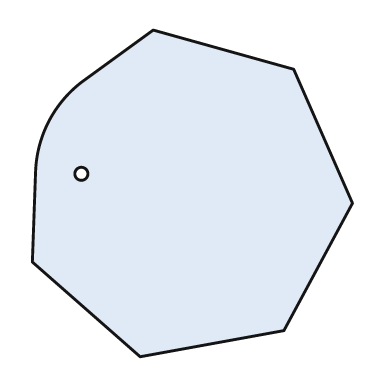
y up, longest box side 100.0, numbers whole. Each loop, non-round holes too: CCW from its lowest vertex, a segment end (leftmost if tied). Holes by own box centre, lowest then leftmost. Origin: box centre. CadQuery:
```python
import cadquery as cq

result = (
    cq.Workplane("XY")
    .moveTo(-16.0, -50.0)
    .lineTo(28.0, -42.0)
    .lineTo(49.0, -3.0)
    .lineTo(31.0, 38.0)
    .lineTo(-12.0, 50.0)
    .lineTo(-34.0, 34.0)
    .threePointArc((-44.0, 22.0), (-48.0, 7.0))
    .lineTo(-49.0, -21.0)
    .close()
    .moveTo(-34.0, 6.0)
    .circle(2.0)
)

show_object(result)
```